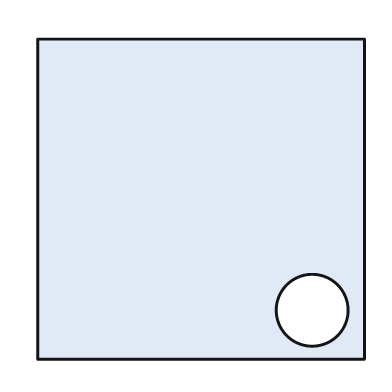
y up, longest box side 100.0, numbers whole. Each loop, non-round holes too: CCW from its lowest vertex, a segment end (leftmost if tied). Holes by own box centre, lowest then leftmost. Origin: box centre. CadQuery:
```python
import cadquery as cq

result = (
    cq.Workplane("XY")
    .moveTo(-50.0, -49.0)
    .lineTo(50.0, -49.0)
    .lineTo(50.0, 49.0)
    .lineTo(-50.0, 49.0)
    .close()
    .moveTo(34.0, -34.0)
    .circle(11.0)
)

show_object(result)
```